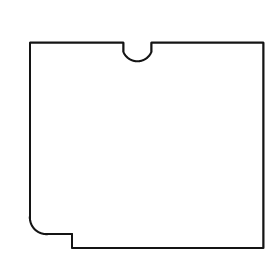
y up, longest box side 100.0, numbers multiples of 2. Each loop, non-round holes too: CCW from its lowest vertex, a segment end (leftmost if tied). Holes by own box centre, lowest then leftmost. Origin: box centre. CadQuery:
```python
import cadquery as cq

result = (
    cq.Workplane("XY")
    .moveTo(-32.0, -44.0)
    .lineTo(50.0, -44.0)
    .lineTo(50.0, 44.0)
    .lineTo(2.0, 44.0)
    .lineTo(2.0, 40.0)
    .threePointArc((-4.0, 36.0), (-10.0, 40.0))
    .lineTo(-10.0, 44.0)
    .lineTo(-50.0, 44.0)
    .lineTo(-50.0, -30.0)
    .threePointArc((-48.0, -36.0), (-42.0, -38.0))
    .lineTo(-32.0, -38.0)
    .close()
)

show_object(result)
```